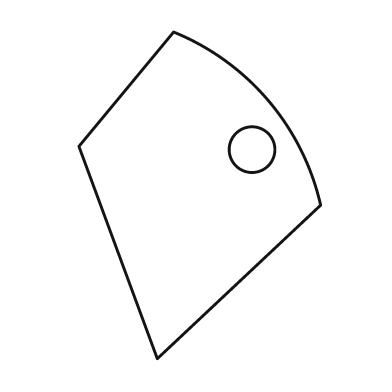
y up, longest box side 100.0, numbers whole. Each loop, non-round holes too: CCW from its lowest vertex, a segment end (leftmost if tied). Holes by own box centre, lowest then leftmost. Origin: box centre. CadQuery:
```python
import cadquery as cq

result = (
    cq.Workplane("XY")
    .moveTo(-13.0, -50.0)
    .lineTo(37.0, -3.0)
    .threePointArc((21.0, 29.0), (-8.0, 50.0))
    .lineTo(-37.0, 15.0)
    .close()
    .moveTo(16.0, 14.0)
    .circle(7.0)
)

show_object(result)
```